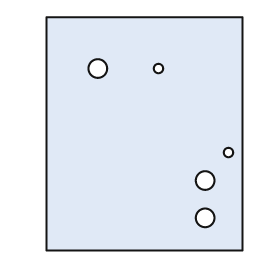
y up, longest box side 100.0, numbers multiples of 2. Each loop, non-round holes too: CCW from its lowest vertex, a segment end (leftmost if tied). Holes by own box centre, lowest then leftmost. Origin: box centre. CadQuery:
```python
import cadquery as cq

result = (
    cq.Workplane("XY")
    .moveTo(-42.0, -50.0)
    .lineTo(42.0, -50.0)
    .lineTo(42.0, 50.0)
    .lineTo(-42.0, 50.0)
    .close()
    .moveTo(26.0, -36.0)
    .circle(4.0)
    .moveTo(26.0, -20.0)
    .circle(4.0)
    .moveTo(36.0, -8.0)
    .circle(2.0)
    .moveTo(-20.0, 28.0)
    .circle(4.0)
    .moveTo(6.0, 28.0)
    .circle(2.0)
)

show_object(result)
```